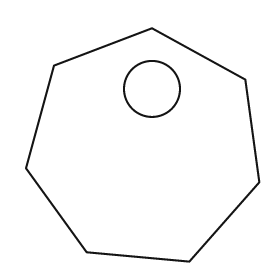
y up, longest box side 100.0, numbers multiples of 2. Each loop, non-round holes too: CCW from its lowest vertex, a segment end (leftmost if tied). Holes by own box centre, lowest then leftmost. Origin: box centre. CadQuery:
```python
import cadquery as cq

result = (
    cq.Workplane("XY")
    .moveTo(20.0, -50.0)
    .lineTo(50.0, -16.0)
    .lineTo(44.0, 28.0)
    .lineTo(4.0, 50.0)
    .lineTo(-38.0, 34.0)
    .lineTo(-50.0, -10.0)
    .lineTo(-24.0, -46.0)
    .close()
    .moveTo(4.0, 24.0)
    .circle(12.0)
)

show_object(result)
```